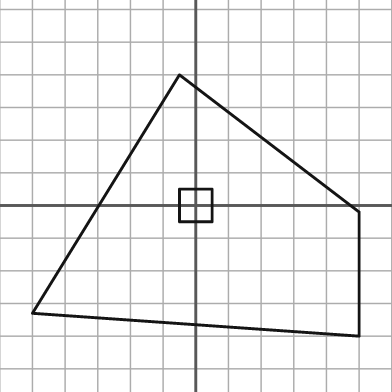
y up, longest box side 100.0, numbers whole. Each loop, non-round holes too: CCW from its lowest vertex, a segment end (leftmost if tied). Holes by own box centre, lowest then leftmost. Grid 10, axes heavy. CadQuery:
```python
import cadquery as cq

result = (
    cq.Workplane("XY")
    .moveTo(50.0, -40.0)
    .lineTo(50.0, -2.0)
    .lineTo(-5.0, 40.0)
    .lineTo(-50.0, -33.0)
    .close()
    .moveTo(-5.0, -5.0)
    .lineTo(5.0, -5.0)
    .lineTo(5.0, 5.0)
    .lineTo(-5.0, 5.0)
    .close()
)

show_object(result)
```